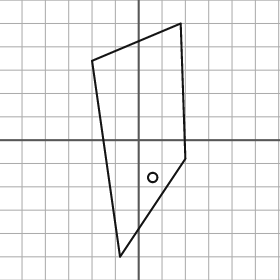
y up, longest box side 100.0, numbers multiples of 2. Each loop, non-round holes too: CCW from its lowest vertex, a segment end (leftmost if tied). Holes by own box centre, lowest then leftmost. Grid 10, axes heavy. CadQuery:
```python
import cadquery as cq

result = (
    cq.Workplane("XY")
    .moveTo(-8.0, -50.0)
    .lineTo(20.0, -8.0)
    .lineTo(18.0, 50.0)
    .lineTo(-20.0, 34.0)
    .close()
    .moveTo(6.0, -16.0)
    .circle(2.0)
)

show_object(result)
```